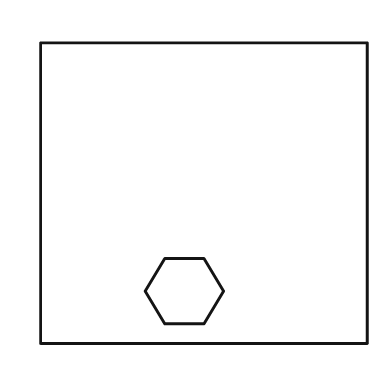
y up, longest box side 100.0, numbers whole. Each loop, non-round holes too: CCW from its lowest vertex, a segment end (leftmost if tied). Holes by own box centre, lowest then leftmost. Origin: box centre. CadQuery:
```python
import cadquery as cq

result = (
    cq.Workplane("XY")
    .moveTo(-50.0, -46.0)
    .lineTo(50.0, -46.0)
    .lineTo(50.0, 46.0)
    .lineTo(-50.0, 46.0)
    .close()
    .moveTo(-12.0, -40.0)
    .lineTo(0.0, -40.0)
    .lineTo(6.0, -30.0)
    .lineTo(0.0, -20.0)
    .lineTo(-12.0, -20.0)
    .lineTo(-18.0, -30.0)
    .close()
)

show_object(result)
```